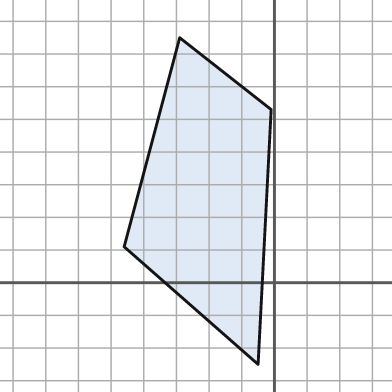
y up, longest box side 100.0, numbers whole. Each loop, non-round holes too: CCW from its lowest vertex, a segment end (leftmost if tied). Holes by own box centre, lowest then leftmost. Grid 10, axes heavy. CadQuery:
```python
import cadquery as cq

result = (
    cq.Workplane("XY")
    .moveTo(-5.0, -25.0)
    .lineTo(-1.0, 53.0)
    .lineTo(-29.0, 75.0)
    .lineTo(-46.0, 11.0)
    .close()
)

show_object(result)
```